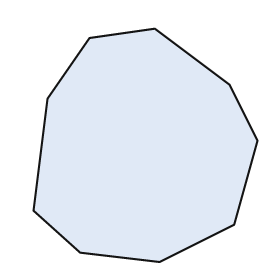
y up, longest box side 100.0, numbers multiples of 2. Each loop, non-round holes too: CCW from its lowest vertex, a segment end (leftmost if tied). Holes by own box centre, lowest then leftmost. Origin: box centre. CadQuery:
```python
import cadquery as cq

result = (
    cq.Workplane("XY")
    .moveTo(6.0, -50.0)
    .lineTo(38.0, -34.0)
    .lineTo(48.0, 2.0)
    .lineTo(36.0, 26.0)
    .lineTo(4.0, 50.0)
    .lineTo(-24.0, 46.0)
    .lineTo(-42.0, 20.0)
    .lineTo(-48.0, -28.0)
    .lineTo(-28.0, -46.0)
    .close()
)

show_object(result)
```